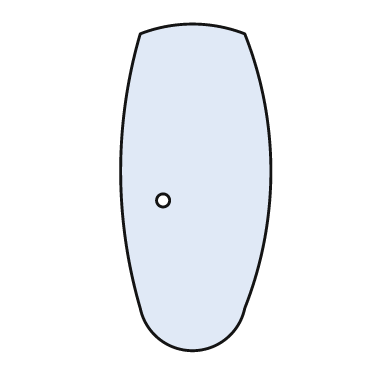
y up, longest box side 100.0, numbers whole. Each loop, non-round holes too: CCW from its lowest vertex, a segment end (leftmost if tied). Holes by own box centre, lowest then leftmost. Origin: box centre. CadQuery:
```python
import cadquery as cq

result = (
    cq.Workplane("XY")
    .moveTo(-17.0, -37.0)
    .threePointArc((-1.0, -50.0), (15.0, -37.0))
    .threePointArc((23.0, 5.0), (15.0, 47.0))
    .threePointArc((-1.0, 50.0), (-17.0, 47.0))
    .threePointArc((-23.0, 5.0), (-17.0, -37.0))
    .close()
    .moveTo(-10.0, -4.0)
    .circle(2.0)
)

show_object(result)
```